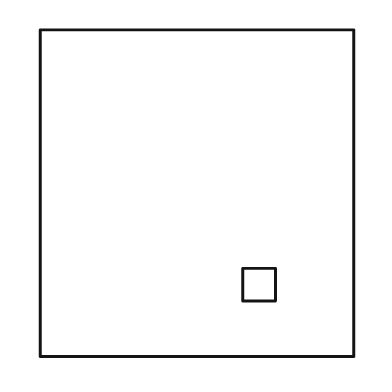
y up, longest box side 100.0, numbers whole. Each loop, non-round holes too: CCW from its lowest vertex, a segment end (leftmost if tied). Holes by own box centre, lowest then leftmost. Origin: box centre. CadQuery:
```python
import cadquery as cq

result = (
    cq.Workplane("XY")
    .moveTo(-48.0, -50.0)
    .lineTo(48.0, -50.0)
    .lineTo(48.0, 50.0)
    .lineTo(-48.0, 50.0)
    .close()
    .moveTo(14.0, -33.0)
    .lineTo(24.0, -33.0)
    .lineTo(24.0, -23.0)
    .lineTo(14.0, -23.0)
    .close()
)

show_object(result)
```